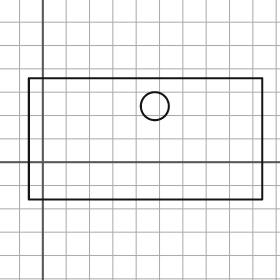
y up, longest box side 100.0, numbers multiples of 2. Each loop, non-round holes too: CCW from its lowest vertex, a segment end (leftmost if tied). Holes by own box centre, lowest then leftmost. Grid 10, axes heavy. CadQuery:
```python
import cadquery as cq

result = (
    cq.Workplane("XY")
    .moveTo(-6.0, -16.0)
    .lineTo(94.0, -16.0)
    .lineTo(94.0, 36.0)
    .lineTo(-6.0, 36.0)
    .close()
    .moveTo(48.0, 24.0)
    .circle(6.0)
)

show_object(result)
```